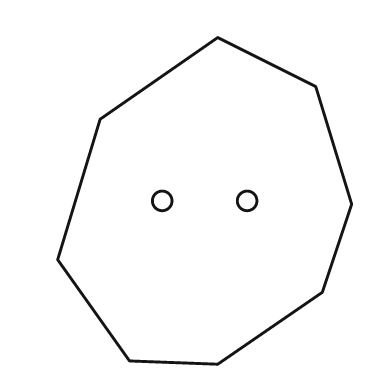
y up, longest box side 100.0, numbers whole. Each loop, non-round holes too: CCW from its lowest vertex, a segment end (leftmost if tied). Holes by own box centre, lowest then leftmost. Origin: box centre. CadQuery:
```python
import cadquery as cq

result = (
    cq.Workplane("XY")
    .moveTo(4.0, -50.0)
    .lineTo(36.0, -28.0)
    .lineTo(45.0, -1.0)
    .lineTo(34.0, 35.0)
    .lineTo(4.0, 50.0)
    .lineTo(-32.0, 25.0)
    .lineTo(-45.0, -18.0)
    .lineTo(-23.0, -49.0)
    .close()
    .moveTo(-13.0, 0.0)
    .circle(3.0)
    .moveTo(13.0, 0.0)
    .circle(3.0)
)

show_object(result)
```